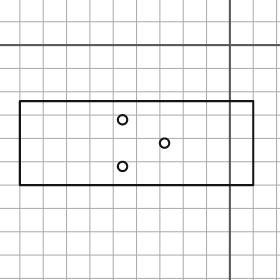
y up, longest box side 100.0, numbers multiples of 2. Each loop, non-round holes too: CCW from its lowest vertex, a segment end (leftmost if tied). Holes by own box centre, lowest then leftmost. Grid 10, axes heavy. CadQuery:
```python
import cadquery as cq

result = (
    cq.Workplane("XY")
    .moveTo(-90.0, -60.0)
    .lineTo(10.0, -60.0)
    .lineTo(10.0, -24.0)
    .lineTo(-90.0, -24.0)
    .close()
    .moveTo(-46.0, -52.0)
    .circle(2.0)
    .moveTo(-28.0, -42.0)
    .circle(2.0)
    .moveTo(-46.0, -32.0)
    .circle(2.0)
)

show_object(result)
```